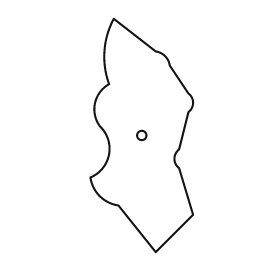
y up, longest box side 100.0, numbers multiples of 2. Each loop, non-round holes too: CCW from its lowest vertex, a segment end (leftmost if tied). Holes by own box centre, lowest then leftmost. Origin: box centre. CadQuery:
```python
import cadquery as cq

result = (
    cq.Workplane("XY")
    .moveTo(6.0, -50.0)
    .lineTo(22.0, -34.0)
    .lineTo(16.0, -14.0)
    .threePointArc((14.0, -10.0), (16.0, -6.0))
    .lineTo(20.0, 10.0)
    .threePointArc((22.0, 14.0), (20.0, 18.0))
    .lineTo(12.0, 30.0)
    .threePointArc((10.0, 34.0), (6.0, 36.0))
    .lineTo(-12.0, 50.0)
    .threePointArc((-16.0, 36.0), (-14.0, 22.0))
    .threePointArc((-20.0, 14.0), (-18.0, 4.0))
    .threePointArc((-14.0, -8.0), (-22.0, -18.0))
    .threePointArc((-18.0, -26.0), (-10.0, -30.0))
    .close()
    .moveTo(0.0, 0.0)
    .circle(2.0)
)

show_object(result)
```